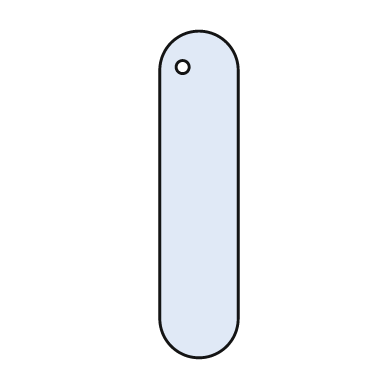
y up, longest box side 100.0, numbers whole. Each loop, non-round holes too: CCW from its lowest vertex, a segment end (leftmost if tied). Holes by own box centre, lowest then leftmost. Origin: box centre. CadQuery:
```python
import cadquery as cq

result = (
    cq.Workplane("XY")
    .moveTo(-12.0, -38.0)
    .threePointArc((0.0, -50.0), (12.0, -38.0))
    .lineTo(12.0, 38.0)
    .threePointArc((0.0, 50.0), (-12.0, 38.0))
    .close()
    .moveTo(-5.0, 39.0)
    .circle(2.0)
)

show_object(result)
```